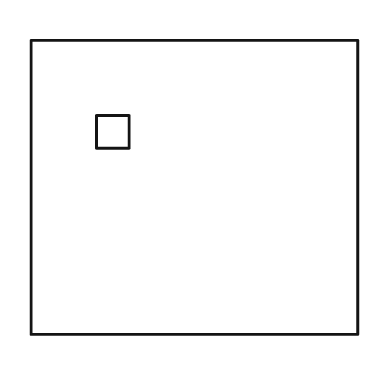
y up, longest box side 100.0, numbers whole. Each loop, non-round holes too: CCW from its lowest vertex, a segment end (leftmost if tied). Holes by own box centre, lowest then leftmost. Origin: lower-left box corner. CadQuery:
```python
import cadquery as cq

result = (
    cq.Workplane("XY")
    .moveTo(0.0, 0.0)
    .lineTo(100.0, 0.0)
    .lineTo(100.0, 90.0)
    .lineTo(0.0, 90.0)
    .close()
    .moveTo(20.0, 57.0)
    .lineTo(30.0, 57.0)
    .lineTo(30.0, 67.0)
    .lineTo(20.0, 67.0)
    .close()
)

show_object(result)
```